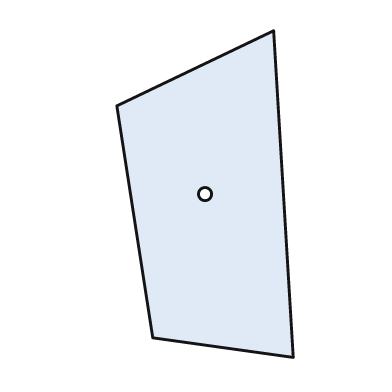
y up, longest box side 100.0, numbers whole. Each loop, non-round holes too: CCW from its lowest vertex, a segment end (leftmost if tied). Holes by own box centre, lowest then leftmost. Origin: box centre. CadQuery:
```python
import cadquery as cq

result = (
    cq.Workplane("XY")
    .moveTo(27.0, -50.0)
    .lineTo(21.0, 50.0)
    .lineTo(-27.0, 27.0)
    .lineTo(-16.0, -44.0)
    .close()
    .moveTo(0.0, 0.0)
    .circle(2.0)
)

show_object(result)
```